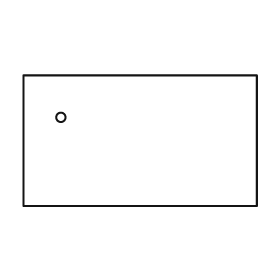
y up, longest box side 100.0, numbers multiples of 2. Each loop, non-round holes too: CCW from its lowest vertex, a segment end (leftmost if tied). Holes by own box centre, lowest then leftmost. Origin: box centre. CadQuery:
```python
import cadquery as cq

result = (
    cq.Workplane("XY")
    .moveTo(-50.0, -28.0)
    .lineTo(50.0, -28.0)
    .lineTo(50.0, 28.0)
    .lineTo(-50.0, 28.0)
    .close()
    .moveTo(-34.0, 10.0)
    .circle(2.0)
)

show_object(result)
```